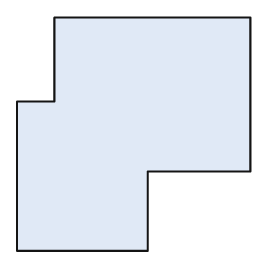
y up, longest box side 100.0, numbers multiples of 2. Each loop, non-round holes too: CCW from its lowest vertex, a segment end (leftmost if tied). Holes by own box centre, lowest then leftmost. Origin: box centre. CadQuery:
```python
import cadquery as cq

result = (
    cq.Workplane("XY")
    .moveTo(-50.0, -50.0)
    .lineTo(6.0, -50.0)
    .lineTo(6.0, -16.0)
    .lineTo(50.0, -16.0)
    .lineTo(50.0, 50.0)
    .lineTo(-34.0, 50.0)
    .lineTo(-34.0, 14.0)
    .lineTo(-50.0, 14.0)
    .close()
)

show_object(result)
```